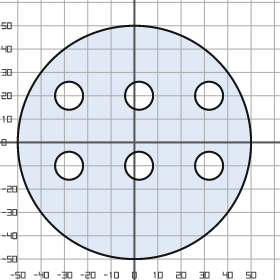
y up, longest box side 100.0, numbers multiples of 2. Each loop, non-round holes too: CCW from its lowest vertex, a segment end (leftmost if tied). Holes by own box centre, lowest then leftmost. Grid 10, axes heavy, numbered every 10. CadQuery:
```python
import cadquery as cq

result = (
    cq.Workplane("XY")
    .moveTo(0.0, 0.0)
    .circle(50.0)
    .moveTo(-28.0, -10.0)
    .circle(6.0)
    .moveTo(2.0, -10.0)
    .circle(6.0)
    .moveTo(32.0, -10.0)
    .circle(6.0)
    .moveTo(-28.0, 20.0)
    .circle(6.0)
    .moveTo(2.0, 20.0)
    .circle(6.0)
    .moveTo(32.0, 20.0)
    .circle(6.0)
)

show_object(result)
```